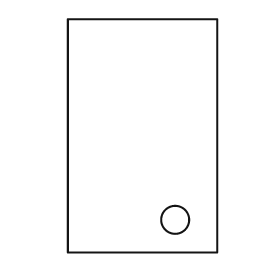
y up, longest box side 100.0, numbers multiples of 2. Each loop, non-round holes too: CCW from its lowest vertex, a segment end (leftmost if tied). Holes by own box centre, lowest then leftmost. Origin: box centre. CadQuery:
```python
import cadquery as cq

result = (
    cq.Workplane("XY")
    .moveTo(-32.0, -50.0)
    .lineTo(32.0, -50.0)
    .lineTo(32.0, 50.0)
    .lineTo(-32.0, 50.0)
    .close()
    .moveTo(14.0, -36.0)
    .circle(6.0)
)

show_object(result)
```